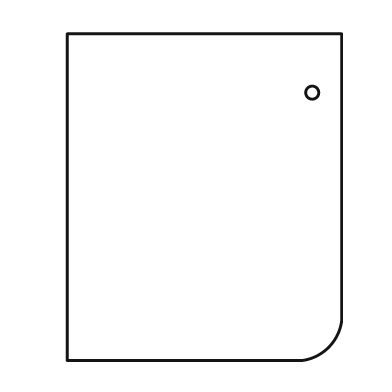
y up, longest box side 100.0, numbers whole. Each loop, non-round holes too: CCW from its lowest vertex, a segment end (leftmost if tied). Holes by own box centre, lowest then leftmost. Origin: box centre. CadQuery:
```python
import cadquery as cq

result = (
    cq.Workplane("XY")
    .moveTo(-42.0, -50.0)
    .lineTo(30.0, -50.0)
    .threePointArc((38.0, -46.0), (42.0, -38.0))
    .lineTo(42.0, 50.0)
    .lineTo(-42.0, 50.0)
    .close()
    .moveTo(33.0, 32.0)
    .circle(2.0)
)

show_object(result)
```